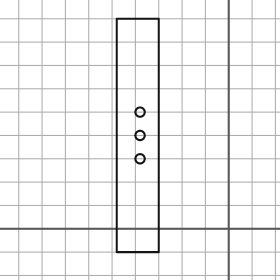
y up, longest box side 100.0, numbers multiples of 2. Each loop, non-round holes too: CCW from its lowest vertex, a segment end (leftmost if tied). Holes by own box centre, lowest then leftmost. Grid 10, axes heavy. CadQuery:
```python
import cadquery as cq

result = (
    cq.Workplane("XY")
    .moveTo(-48.0, -10.0)
    .lineTo(-30.0, -10.0)
    .lineTo(-30.0, 90.0)
    .lineTo(-48.0, 90.0)
    .close()
    .moveTo(-38.0, 30.0)
    .circle(2.0)
    .moveTo(-38.0, 40.0)
    .circle(2.0)
    .moveTo(-38.0, 50.0)
    .circle(2.0)
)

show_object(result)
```